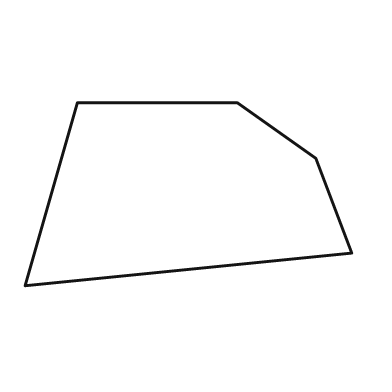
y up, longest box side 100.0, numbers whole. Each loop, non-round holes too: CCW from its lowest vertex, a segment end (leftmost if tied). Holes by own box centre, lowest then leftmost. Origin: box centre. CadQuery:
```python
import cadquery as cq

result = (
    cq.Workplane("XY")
    .moveTo(-50.0, -28.0)
    .lineTo(50.0, -18.0)
    .lineTo(39.0, 11.0)
    .lineTo(15.0, 28.0)
    .lineTo(-34.0, 28.0)
    .close()
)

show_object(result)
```